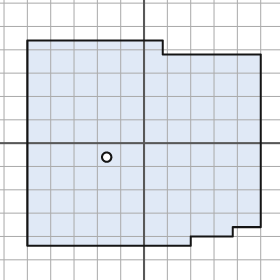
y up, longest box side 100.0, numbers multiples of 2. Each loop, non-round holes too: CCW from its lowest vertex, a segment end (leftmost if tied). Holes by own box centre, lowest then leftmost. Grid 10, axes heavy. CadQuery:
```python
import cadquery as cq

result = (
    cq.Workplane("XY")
    .moveTo(-50.0, -44.0)
    .lineTo(20.0, -44.0)
    .lineTo(20.0, -40.0)
    .lineTo(38.0, -40.0)
    .lineTo(38.0, -36.0)
    .lineTo(50.0, -36.0)
    .lineTo(50.0, 38.0)
    .lineTo(8.0, 38.0)
    .lineTo(8.0, 44.0)
    .lineTo(-50.0, 44.0)
    .close()
    .moveTo(-16.0, -6.0)
    .circle(2.0)
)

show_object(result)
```